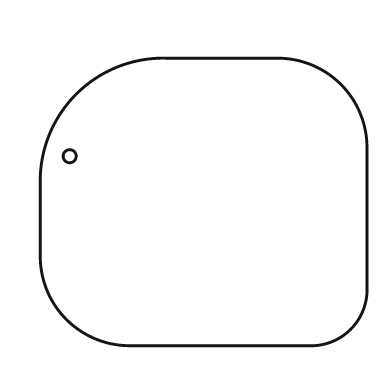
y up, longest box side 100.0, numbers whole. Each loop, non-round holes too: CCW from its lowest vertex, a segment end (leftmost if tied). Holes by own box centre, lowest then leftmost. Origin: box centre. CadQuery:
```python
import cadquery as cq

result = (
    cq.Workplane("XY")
    .moveTo(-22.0, -44.0)
    .lineTo(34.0, -44.0)
    .threePointArc((45.0, -39.0), (50.0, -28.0))
    .lineTo(50.0, 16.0)
    .threePointArc((42.0, 36.0), (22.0, 44.0))
    .lineTo(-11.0, 44.0)
    .threePointArc((-39.0, 33.0), (-50.0, 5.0))
    .lineTo(-50.0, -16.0)
    .threePointArc((-42.0, -36.0), (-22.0, -44.0))
    .close()
    .moveTo(-41.0, 14.0)
    .circle(2.0)
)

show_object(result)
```